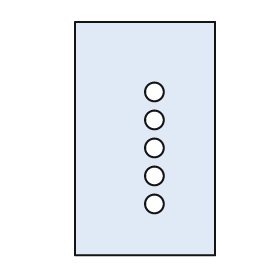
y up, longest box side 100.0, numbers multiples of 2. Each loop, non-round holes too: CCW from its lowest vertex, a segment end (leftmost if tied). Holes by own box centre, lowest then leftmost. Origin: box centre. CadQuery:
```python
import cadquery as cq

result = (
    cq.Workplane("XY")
    .moveTo(-30.0, -50.0)
    .lineTo(30.0, -50.0)
    .lineTo(30.0, 50.0)
    .lineTo(-30.0, 50.0)
    .close()
    .moveTo(4.0, -28.0)
    .circle(4.0)
    .moveTo(4.0, -16.0)
    .circle(4.0)
    .moveTo(4.0, -4.0)
    .circle(4.0)
    .moveTo(4.0, 8.0)
    .circle(4.0)
    .moveTo(4.0, 20.0)
    .circle(4.0)
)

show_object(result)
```